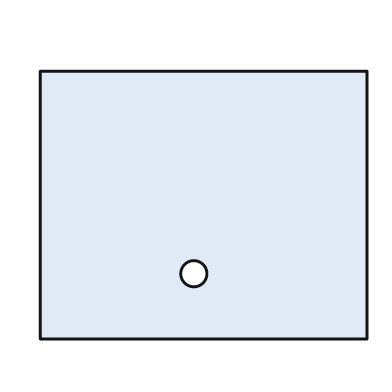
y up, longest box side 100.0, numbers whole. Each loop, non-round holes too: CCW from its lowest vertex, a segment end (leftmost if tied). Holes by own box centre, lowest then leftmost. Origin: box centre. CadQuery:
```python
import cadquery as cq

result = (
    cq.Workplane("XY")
    .moveTo(-50.0, -41.0)
    .lineTo(50.0, -41.0)
    .lineTo(50.0, 41.0)
    .lineTo(-50.0, 41.0)
    .close()
    .moveTo(-3.0, -21.0)
    .circle(4.0)
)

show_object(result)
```